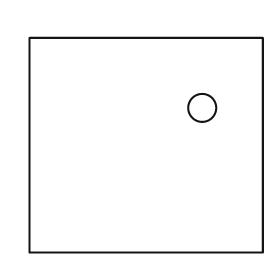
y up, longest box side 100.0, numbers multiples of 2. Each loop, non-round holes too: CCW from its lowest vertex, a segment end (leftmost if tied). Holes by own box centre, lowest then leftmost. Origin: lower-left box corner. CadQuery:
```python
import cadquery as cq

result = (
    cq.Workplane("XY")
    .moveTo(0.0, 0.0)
    .lineTo(100.0, 0.0)
    .lineTo(100.0, 92.0)
    .lineTo(0.0, 92.0)
    .close()
    .moveTo(74.0, 62.0)
    .circle(6.0)
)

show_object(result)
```